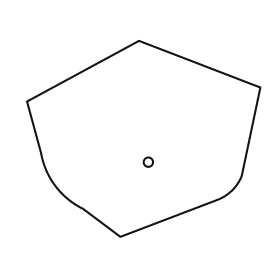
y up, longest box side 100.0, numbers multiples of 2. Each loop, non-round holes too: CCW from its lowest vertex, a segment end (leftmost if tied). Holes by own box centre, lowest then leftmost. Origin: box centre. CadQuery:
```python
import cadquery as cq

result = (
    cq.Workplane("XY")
    .moveTo(-10.0, -42.0)
    .lineTo(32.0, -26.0)
    .threePointArc((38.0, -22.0), (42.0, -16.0))
    .lineTo(50.0, 22.0)
    .lineTo(-2.0, 42.0)
    .lineTo(-50.0, 16.0)
    .lineTo(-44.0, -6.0)
    .threePointArc((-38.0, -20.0), (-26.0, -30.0))
    .close()
    .moveTo(2.0, -10.0)
    .circle(2.0)
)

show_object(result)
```